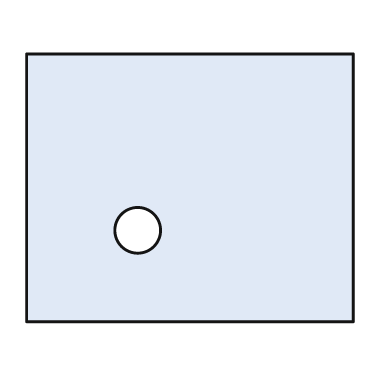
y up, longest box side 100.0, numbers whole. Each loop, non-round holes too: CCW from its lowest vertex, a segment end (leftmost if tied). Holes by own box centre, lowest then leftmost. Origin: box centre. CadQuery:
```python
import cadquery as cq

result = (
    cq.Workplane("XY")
    .moveTo(-50.0, -41.0)
    .lineTo(50.0, -41.0)
    .lineTo(50.0, 41.0)
    .lineTo(-50.0, 41.0)
    .close()
    .moveTo(-16.0, -13.0)
    .circle(7.0)
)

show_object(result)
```